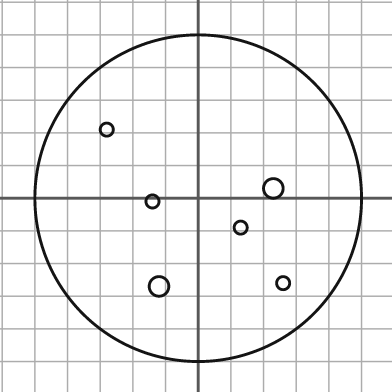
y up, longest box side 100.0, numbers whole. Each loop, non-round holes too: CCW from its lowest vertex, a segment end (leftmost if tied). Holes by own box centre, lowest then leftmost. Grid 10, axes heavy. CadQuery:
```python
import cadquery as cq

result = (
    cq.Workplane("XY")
    .moveTo(0.0, 0.0)
    .circle(50.0)
    .moveTo(-12.0, -27.0)
    .circle(3.0)
    .moveTo(26.0, -26.0)
    .circle(2.0)
    .moveTo(13.0, -9.0)
    .circle(2.0)
    .moveTo(-14.0, -1.0)
    .circle(2.0)
    .moveTo(23.0, 3.0)
    .circle(3.0)
    .moveTo(-28.0, 21.0)
    .circle(2.0)
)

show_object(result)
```